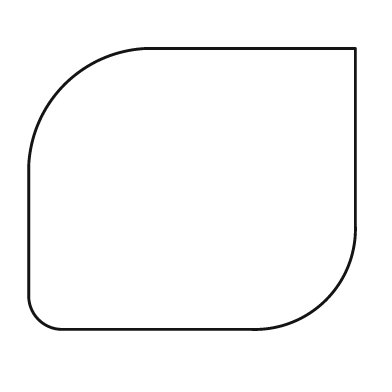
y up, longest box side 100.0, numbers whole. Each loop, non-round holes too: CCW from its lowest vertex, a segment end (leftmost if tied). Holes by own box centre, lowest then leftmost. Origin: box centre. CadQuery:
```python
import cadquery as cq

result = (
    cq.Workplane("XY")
    .moveTo(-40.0, -43.0)
    .lineTo(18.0, -43.0)
    .threePointArc((41.0, -34.0), (50.0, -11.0))
    .lineTo(50.0, 43.0)
    .lineTo(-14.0, 43.0)
    .threePointArc((-39.0, 32.0), (-50.0, 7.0))
    .lineTo(-50.0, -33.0)
    .threePointArc((-47.0, -40.0), (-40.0, -43.0))
    .close()
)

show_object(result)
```